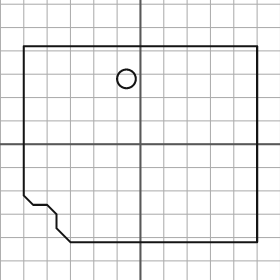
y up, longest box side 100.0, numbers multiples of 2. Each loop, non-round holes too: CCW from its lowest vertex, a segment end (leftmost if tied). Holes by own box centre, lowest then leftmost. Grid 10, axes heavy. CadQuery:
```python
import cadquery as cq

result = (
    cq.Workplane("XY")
    .moveTo(-30.0, -42.0)
    .lineTo(50.0, -42.0)
    .lineTo(50.0, 42.0)
    .lineTo(-50.0, 42.0)
    .lineTo(-50.0, -22.0)
    .lineTo(-46.0, -26.0)
    .lineTo(-40.0, -26.0)
    .lineTo(-36.0, -30.0)
    .lineTo(-36.0, -36.0)
    .close()
    .moveTo(-6.0, 28.0)
    .circle(4.0)
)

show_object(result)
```